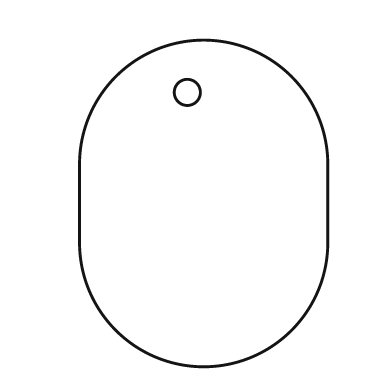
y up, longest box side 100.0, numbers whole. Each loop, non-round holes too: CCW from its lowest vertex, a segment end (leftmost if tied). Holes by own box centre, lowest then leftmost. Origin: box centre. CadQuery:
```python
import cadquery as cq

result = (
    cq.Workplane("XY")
    .moveTo(-38.0, -12.0)
    .threePointArc((0.0, -50.0), (38.0, -12.0))
    .lineTo(38.0, 12.0)
    .threePointArc((0.0, 50.0), (-38.0, 12.0))
    .close()
    .moveTo(-5.0, 34.0)
    .circle(4.0)
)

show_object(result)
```